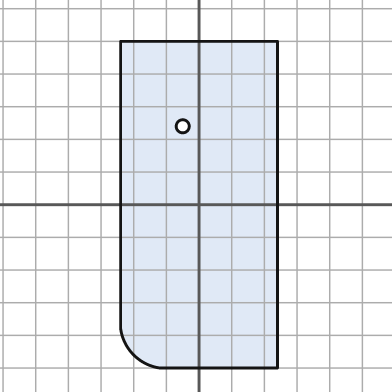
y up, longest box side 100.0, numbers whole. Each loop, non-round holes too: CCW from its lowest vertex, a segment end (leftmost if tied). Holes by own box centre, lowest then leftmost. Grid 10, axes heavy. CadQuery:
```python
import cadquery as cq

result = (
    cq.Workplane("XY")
    .moveTo(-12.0, -50.0)
    .lineTo(24.0, -50.0)
    .lineTo(24.0, 50.0)
    .lineTo(-24.0, 50.0)
    .lineTo(-24.0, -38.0)
    .threePointArc((-20.0, -46.0), (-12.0, -50.0))
    .close()
    .moveTo(-5.0, 24.0)
    .circle(2.0)
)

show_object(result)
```